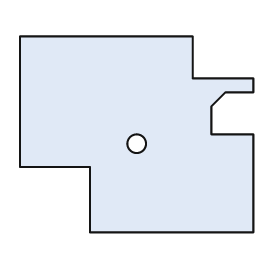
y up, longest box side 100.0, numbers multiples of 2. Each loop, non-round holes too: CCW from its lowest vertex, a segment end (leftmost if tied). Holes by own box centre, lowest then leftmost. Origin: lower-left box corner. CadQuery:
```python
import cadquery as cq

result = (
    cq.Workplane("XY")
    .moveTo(30.0, 0.0)
    .lineTo(100.0, 0.0)
    .lineTo(100.0, 42.0)
    .lineTo(82.0, 42.0)
    .lineTo(82.0, 54.0)
    .lineTo(88.0, 60.0)
    .lineTo(100.0, 60.0)
    .lineTo(100.0, 66.0)
    .lineTo(74.0, 66.0)
    .lineTo(74.0, 84.0)
    .lineTo(0.0, 84.0)
    .lineTo(0.0, 28.0)
    .lineTo(30.0, 28.0)
    .close()
    .moveTo(50.0, 38.0)
    .circle(4.0)
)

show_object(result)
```